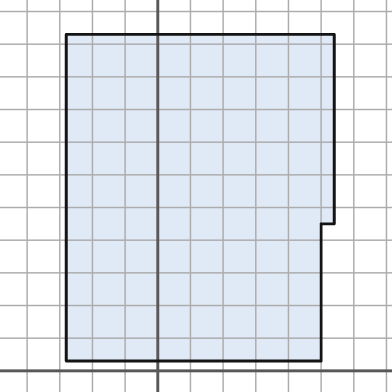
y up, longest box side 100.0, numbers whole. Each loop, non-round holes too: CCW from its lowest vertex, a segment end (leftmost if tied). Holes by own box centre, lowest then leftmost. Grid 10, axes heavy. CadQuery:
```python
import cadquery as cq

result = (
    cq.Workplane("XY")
    .moveTo(-28.0, 3.0)
    .lineTo(50.0, 3.0)
    .lineTo(50.0, 45.0)
    .lineTo(54.0, 45.0)
    .lineTo(54.0, 103.0)
    .lineTo(-28.0, 103.0)
    .close()
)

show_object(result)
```